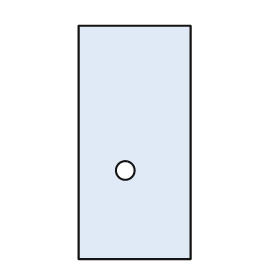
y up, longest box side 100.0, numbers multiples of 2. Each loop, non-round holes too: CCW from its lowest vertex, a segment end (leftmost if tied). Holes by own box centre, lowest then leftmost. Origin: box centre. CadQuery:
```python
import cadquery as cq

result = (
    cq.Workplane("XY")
    .moveTo(-24.0, -50.0)
    .lineTo(24.0, -50.0)
    .lineTo(24.0, 50.0)
    .lineTo(-24.0, 50.0)
    .close()
    .moveTo(-4.0, -12.0)
    .circle(4.0)
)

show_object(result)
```